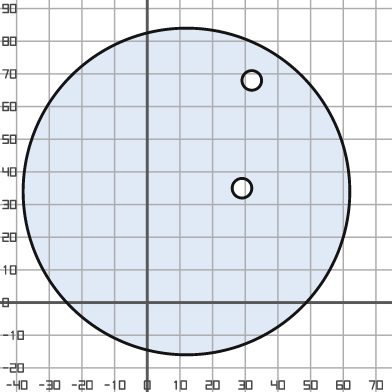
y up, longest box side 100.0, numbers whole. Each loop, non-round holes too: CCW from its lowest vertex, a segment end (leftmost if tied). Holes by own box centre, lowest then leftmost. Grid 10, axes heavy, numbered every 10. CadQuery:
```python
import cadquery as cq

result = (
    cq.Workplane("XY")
    .moveTo(12.0, 34.0)
    .circle(50.0)
    .moveTo(29.0, 35.0)
    .circle(3.0)
    .moveTo(32.0, 68.0)
    .circle(3.0)
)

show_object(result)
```